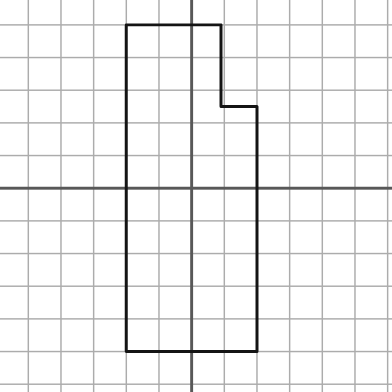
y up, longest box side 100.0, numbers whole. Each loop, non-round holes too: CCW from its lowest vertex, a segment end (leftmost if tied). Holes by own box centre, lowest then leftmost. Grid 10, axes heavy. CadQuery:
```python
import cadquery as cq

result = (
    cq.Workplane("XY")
    .moveTo(-20.0, -50.0)
    .lineTo(20.0, -50.0)
    .lineTo(20.0, 25.0)
    .lineTo(9.0, 25.0)
    .lineTo(9.0, 50.0)
    .lineTo(-20.0, 50.0)
    .close()
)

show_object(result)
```